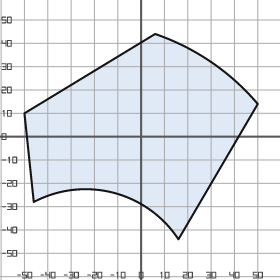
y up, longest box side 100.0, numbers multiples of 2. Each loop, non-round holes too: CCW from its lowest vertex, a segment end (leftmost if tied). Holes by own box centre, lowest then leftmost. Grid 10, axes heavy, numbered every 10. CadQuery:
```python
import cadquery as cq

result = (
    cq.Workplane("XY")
    .moveTo(16.0, -44.0)
    .lineTo(50.0, 14.0)
    .threePointArc((30.0, 32.0), (6.0, 44.0))
    .lineTo(-50.0, 10.0)
    .lineTo(-46.0, -28.0)
    .threePointArc((-12.0, -24.0), (16.0, -44.0))
    .close()
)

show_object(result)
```